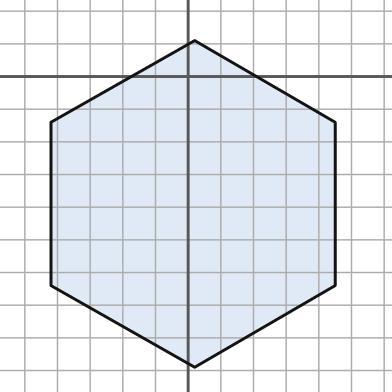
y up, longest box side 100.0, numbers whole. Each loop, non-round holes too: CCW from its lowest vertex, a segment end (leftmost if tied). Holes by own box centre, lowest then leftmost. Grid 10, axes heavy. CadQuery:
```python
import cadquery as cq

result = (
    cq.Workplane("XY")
    .moveTo(2.0, -89.0)
    .lineTo(45.0, -64.0)
    .lineTo(45.0, -14.0)
    .lineTo(2.0, 11.0)
    .lineTo(-42.0, -14.0)
    .lineTo(-42.0, -64.0)
    .close()
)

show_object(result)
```